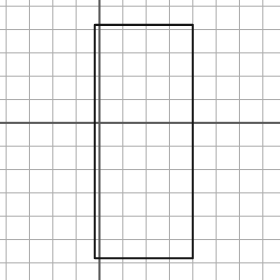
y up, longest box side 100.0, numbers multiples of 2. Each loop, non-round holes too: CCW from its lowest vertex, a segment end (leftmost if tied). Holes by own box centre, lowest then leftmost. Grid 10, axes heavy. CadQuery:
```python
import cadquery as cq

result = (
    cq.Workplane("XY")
    .moveTo(-2.0, -58.0)
    .lineTo(40.0, -58.0)
    .lineTo(40.0, 42.0)
    .lineTo(-2.0, 42.0)
    .close()
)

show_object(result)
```